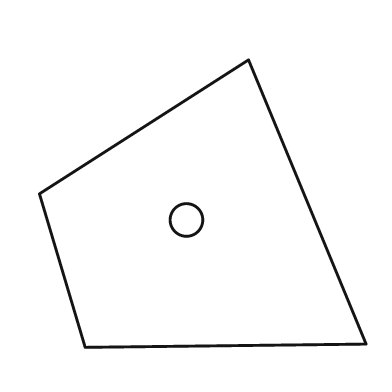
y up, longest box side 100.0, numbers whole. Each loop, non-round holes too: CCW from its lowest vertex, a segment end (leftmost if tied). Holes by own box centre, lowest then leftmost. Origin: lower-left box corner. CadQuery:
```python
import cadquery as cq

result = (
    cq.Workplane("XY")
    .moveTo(14.0, 0.0)
    .lineTo(100.0, 1.0)
    .lineTo(64.0, 88.0)
    .lineTo(0.0, 47.0)
    .close()
    .moveTo(45.0, 39.0)
    .circle(5.0)
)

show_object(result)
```